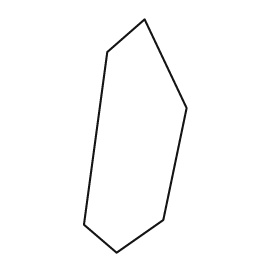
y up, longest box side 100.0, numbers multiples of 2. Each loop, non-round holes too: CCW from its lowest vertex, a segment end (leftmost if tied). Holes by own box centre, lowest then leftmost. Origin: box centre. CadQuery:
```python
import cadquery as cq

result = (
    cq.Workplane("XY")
    .moveTo(-8.0, -50.0)
    .lineTo(12.0, -36.0)
    .lineTo(22.0, 12.0)
    .lineTo(4.0, 50.0)
    .lineTo(-12.0, 36.0)
    .lineTo(-22.0, -38.0)
    .close()
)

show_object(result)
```